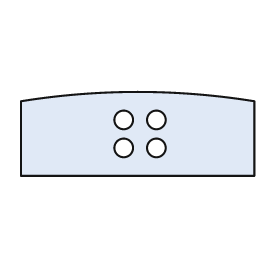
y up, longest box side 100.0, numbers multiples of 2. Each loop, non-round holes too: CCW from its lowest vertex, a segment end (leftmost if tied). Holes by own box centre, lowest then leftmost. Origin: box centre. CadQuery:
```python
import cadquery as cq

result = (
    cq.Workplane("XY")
    .moveTo(-50.0, -18.0)
    .lineTo(50.0, -18.0)
    .lineTo(50.0, 14.0)
    .threePointArc((0.0, 18.0), (-50.0, 14.0))
    .close()
    .moveTo(-6.0, -6.0)
    .circle(4.0)
    .moveTo(8.0, -6.0)
    .circle(4.0)
    .moveTo(-6.0, 6.0)
    .circle(4.0)
    .moveTo(8.0, 6.0)
    .circle(4.0)
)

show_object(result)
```